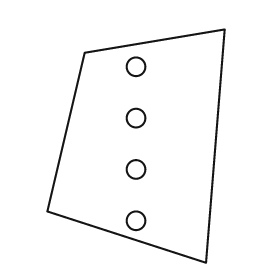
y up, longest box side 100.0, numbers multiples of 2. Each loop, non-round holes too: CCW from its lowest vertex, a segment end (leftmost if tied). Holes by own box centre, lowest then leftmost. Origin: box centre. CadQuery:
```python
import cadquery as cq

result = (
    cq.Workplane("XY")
    .moveTo(30.0, -50.0)
    .lineTo(38.0, 50.0)
    .lineTo(-22.0, 40.0)
    .lineTo(-38.0, -28.0)
    .close()
    .moveTo(0.0, -32.0)
    .circle(4.0)
    .moveTo(0.0, -10.0)
    .circle(4.0)
    .moveTo(0.0, 12.0)
    .circle(4.0)
    .moveTo(0.0, 34.0)
    .circle(4.0)
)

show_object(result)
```